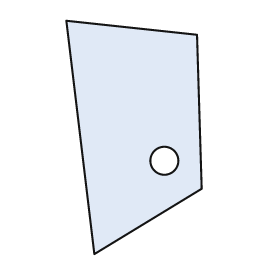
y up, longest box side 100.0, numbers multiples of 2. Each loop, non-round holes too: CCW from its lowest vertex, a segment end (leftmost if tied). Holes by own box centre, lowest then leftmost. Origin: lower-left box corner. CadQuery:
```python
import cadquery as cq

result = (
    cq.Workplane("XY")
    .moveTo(12.0, 0.0)
    .lineTo(58.0, 28.0)
    .lineTo(56.0, 94.0)
    .lineTo(0.0, 100.0)
    .close()
    .moveTo(42.0, 40.0)
    .circle(6.0)
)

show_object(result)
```